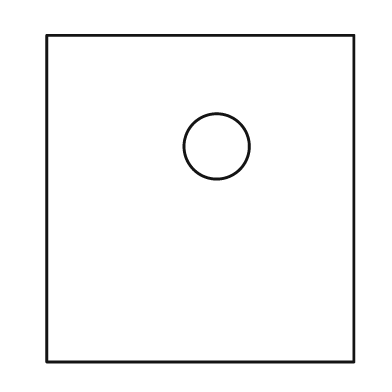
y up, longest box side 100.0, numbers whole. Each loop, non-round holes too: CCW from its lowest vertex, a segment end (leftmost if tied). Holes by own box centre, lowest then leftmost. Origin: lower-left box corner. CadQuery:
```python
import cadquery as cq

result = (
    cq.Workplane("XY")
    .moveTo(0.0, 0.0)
    .lineTo(94.0, 0.0)
    .lineTo(94.0, 100.0)
    .lineTo(0.0, 100.0)
    .close()
    .moveTo(52.0, 66.0)
    .circle(10.0)
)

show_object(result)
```